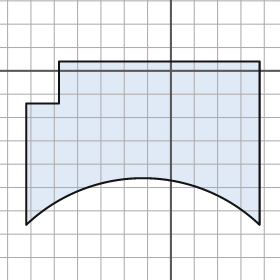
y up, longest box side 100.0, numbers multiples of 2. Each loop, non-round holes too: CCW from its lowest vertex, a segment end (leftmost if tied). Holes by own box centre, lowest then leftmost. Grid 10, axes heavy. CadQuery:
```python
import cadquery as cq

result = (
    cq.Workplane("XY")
    .moveTo(-62.0, -66.0)
    .threePointArc((-12.0, -46.0), (38.0, -66.0))
    .lineTo(38.0, 4.0)
    .lineTo(-48.0, 4.0)
    .lineTo(-48.0, -14.0)
    .lineTo(-62.0, -14.0)
    .close()
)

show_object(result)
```